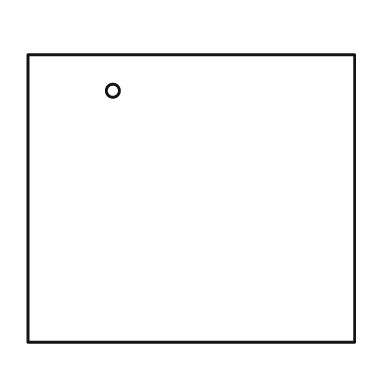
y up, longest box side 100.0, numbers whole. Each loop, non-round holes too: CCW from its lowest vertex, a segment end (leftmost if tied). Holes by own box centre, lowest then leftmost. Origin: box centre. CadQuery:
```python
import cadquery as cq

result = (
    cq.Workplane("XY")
    .moveTo(-50.0, -44.0)
    .lineTo(50.0, -44.0)
    .lineTo(50.0, 44.0)
    .lineTo(-50.0, 44.0)
    .close()
    .moveTo(-24.0, 33.0)
    .circle(2.0)
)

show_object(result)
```